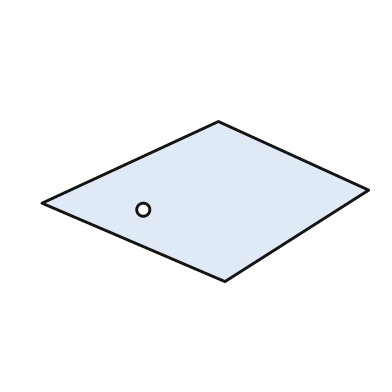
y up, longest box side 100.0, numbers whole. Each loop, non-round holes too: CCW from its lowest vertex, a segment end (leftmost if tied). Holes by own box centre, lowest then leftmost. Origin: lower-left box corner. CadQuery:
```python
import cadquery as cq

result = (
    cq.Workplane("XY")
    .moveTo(56.0, 0.0)
    .lineTo(100.0, 28.0)
    .lineTo(54.0, 49.0)
    .lineTo(0.0, 24.0)
    .close()
    .moveTo(31.0, 22.0)
    .circle(2.0)
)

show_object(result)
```